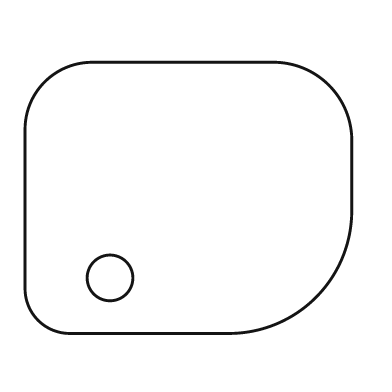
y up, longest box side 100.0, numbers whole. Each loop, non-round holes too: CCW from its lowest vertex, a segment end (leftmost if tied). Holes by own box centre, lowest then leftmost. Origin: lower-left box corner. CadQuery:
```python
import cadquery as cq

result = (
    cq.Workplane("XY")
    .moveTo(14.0, 0.0)
    .lineTo(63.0, 0.0)
    .threePointArc((89.0, 11.0), (100.0, 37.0))
    .lineTo(100.0, 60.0)
    .threePointArc((93.0, 76.0), (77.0, 83.0))
    .lineTo(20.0, 83.0)
    .threePointArc((6.0, 77.0), (0.0, 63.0))
    .lineTo(0.0, 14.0)
    .threePointArc((4.0, 4.0), (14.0, 0.0))
    .close()
    .moveTo(26.0, 17.0)
    .circle(7.0)
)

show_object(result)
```